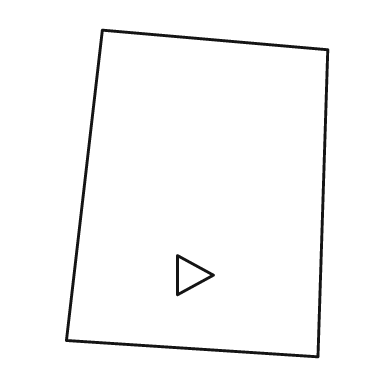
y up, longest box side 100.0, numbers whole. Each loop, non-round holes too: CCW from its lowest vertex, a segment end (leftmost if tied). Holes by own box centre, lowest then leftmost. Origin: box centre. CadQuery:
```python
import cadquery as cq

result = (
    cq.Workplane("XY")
    .moveTo(37.0, -50.0)
    .lineTo(40.0, 44.0)
    .lineTo(-29.0, 50.0)
    .lineTo(-40.0, -45.0)
    .close()
    .moveTo(-6.0, -31.0)
    .lineTo(5.0, -25.0)
    .lineTo(-6.0, -19.0)
    .close()
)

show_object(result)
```